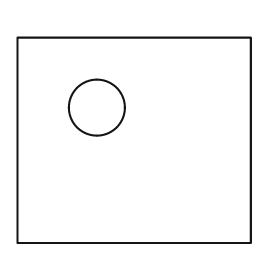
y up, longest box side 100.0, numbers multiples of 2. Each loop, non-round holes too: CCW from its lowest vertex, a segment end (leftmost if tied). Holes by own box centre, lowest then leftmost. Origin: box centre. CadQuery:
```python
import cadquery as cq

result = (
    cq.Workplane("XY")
    .moveTo(-50.0, -44.0)
    .lineTo(50.0, -44.0)
    .lineTo(50.0, 44.0)
    .lineTo(-50.0, 44.0)
    .close()
    .moveTo(-16.0, 14.0)
    .circle(12.0)
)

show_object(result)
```